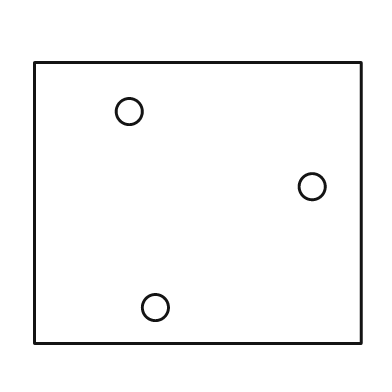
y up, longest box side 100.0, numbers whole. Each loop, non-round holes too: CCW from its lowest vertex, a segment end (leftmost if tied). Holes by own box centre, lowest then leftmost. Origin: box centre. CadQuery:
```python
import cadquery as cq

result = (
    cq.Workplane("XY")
    .moveTo(-50.0, -43.0)
    .lineTo(50.0, -43.0)
    .lineTo(50.0, 43.0)
    .lineTo(-50.0, 43.0)
    .close()
    .moveTo(-13.0, -32.0)
    .circle(4.0)
    .moveTo(35.0, 5.0)
    .circle(4.0)
    .moveTo(-21.0, 28.0)
    .circle(4.0)
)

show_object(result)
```